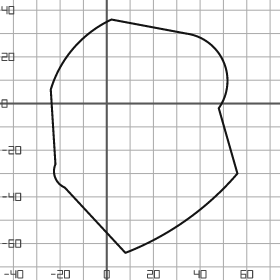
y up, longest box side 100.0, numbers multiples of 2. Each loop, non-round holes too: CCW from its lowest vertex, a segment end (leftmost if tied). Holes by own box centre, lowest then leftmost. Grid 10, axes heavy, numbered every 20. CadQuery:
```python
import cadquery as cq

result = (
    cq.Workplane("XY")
    .moveTo(8.0, -64.0)
    .threePointArc((34.0, -50.0), (56.0, -30.0))
    .lineTo(48.0, -2.0)
    .threePointArc((50.0, 18.0), (34.0, 30.0))
    .lineTo(2.0, 36.0)
    .threePointArc((-14.0, 24.0), (-24.0, 6.0))
    .lineTo(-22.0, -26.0)
    .threePointArc((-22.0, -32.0), (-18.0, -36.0))
    .close()
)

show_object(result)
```